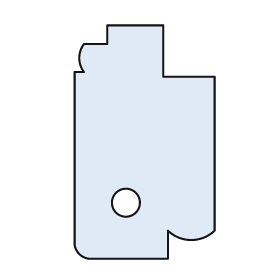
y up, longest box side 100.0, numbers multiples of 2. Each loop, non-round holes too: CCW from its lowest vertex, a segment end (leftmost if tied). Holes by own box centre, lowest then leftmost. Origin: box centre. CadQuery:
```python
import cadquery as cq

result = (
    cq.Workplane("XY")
    .moveTo(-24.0, -50.0)
    .lineTo(10.0, -50.0)
    .lineTo(10.0, -38.0)
    .threePointArc((20.0, -42.0), (30.0, -38.0))
    .lineTo(30.0, 28.0)
    .lineTo(8.0, 28.0)
    .lineTo(8.0, 50.0)
    .lineTo(-16.0, 50.0)
    .lineTo(-16.0, 42.0)
    .lineTo(-26.0, 42.0)
    .threePointArc((-28.0, 36.0), (-26.0, 30.0))
    .lineTo(-30.0, 30.0)
    .lineTo(-30.0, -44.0)
    .threePointArc((-28.0, -48.0), (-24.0, -50.0))
    .close()
    .moveTo(-8.0, -26.0)
    .circle(6.0)
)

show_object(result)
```